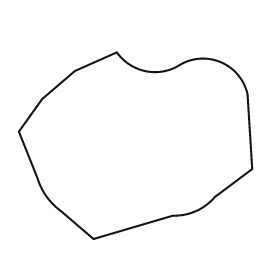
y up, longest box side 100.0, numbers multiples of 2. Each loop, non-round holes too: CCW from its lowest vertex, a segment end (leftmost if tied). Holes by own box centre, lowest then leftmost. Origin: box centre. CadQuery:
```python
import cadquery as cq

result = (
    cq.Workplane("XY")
    .moveTo(-18.0, -40.0)
    .lineTo(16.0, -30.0)
    .threePointArc((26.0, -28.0), (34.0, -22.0))
    .lineTo(50.0, -10.0)
    .lineTo(48.0, 22.0)
    .threePointArc((36.0, 36.0), (18.0, 34.0))
    .threePointArc((4.0, 32.0), (-8.0, 40.0))
    .lineTo(-26.0, 32.0)
    .lineTo(-40.0, 20.0)
    .lineTo(-50.0, 6.0)
    .lineTo(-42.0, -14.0)
    .threePointArc((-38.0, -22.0), (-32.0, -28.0))
    .close()
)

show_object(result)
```